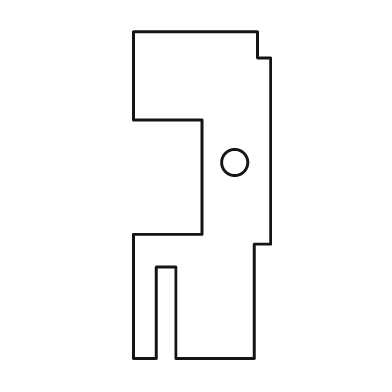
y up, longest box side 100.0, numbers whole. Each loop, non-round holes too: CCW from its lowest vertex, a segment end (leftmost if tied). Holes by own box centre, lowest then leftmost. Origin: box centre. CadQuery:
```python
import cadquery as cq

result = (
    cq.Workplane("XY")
    .moveTo(-21.0, -50.0)
    .lineTo(-14.0, -50.0)
    .lineTo(-14.0, -22.0)
    .lineTo(-8.0, -22.0)
    .lineTo(-8.0, -50.0)
    .lineTo(16.0, -50.0)
    .lineTo(16.0, -15.0)
    .lineTo(21.0, -15.0)
    .lineTo(21.0, 42.0)
    .lineTo(17.0, 42.0)
    .lineTo(17.0, 50.0)
    .lineTo(-21.0, 50.0)
    .lineTo(-21.0, 23.0)
    .lineTo(0.0, 23.0)
    .lineTo(0.0, -12.0)
    .lineTo(-21.0, -12.0)
    .close()
    .moveTo(10.0, 10.0)
    .circle(4.0)
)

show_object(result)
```